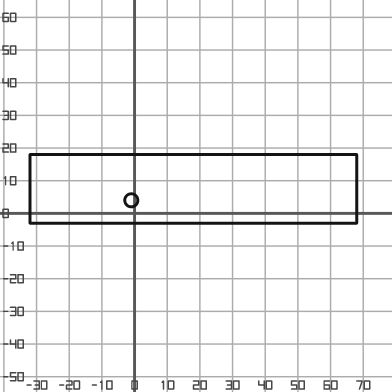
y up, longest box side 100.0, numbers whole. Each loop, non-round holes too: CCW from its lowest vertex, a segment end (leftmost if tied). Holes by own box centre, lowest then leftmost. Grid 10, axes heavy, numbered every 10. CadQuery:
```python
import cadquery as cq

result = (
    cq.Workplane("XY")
    .moveTo(-32.0, -3.0)
    .lineTo(68.0, -3.0)
    .lineTo(68.0, 18.0)
    .lineTo(-32.0, 18.0)
    .close()
    .moveTo(-1.0, 4.0)
    .circle(2.0)
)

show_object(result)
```